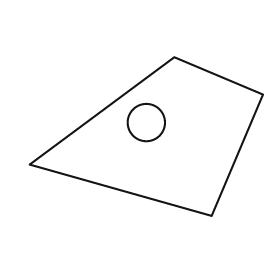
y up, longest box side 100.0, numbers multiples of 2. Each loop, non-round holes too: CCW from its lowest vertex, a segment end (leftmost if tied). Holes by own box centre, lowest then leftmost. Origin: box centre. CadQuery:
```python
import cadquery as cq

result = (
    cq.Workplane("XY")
    .moveTo(28.0, -34.0)
    .lineTo(50.0, 18.0)
    .lineTo(12.0, 34.0)
    .lineTo(-50.0, -12.0)
    .close()
    .moveTo(0.0, 6.0)
    .circle(8.0)
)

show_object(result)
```